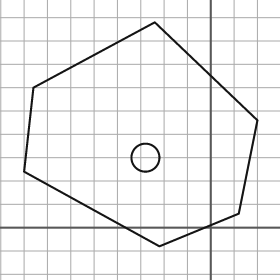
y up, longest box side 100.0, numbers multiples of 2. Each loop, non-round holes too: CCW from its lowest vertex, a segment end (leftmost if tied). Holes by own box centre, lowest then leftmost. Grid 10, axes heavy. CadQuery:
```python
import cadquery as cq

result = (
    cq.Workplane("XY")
    .moveTo(-22.0, -8.0)
    .lineTo(12.0, 6.0)
    .lineTo(20.0, 46.0)
    .lineTo(-24.0, 88.0)
    .lineTo(-76.0, 60.0)
    .lineTo(-80.0, 24.0)
    .close()
    .moveTo(-28.0, 30.0)
    .circle(6.0)
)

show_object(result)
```